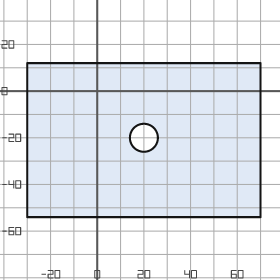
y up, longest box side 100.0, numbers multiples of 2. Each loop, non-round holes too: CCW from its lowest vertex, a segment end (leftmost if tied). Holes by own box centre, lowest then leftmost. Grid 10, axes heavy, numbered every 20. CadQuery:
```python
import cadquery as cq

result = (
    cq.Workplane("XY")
    .moveTo(-30.0, -54.0)
    .lineTo(70.0, -54.0)
    .lineTo(70.0, 12.0)
    .lineTo(-30.0, 12.0)
    .close()
    .moveTo(20.0, -20.0)
    .circle(6.0)
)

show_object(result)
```